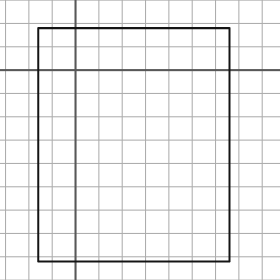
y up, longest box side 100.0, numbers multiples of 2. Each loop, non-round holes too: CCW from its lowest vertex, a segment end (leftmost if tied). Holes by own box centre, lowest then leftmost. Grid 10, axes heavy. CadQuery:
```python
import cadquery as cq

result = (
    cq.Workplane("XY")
    .moveTo(-16.0, -82.0)
    .lineTo(66.0, -82.0)
    .lineTo(66.0, 18.0)
    .lineTo(-16.0, 18.0)
    .close()
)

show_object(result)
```